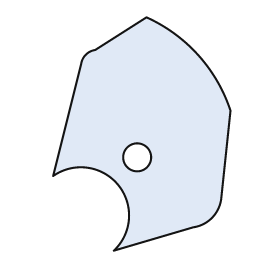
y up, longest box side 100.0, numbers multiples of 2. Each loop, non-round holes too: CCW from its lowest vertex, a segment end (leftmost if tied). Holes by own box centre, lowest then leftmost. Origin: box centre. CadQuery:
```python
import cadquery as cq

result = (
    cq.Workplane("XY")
    .moveTo(-12.0, -50.0)
    .lineTo(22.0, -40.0)
    .threePointArc((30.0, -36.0), (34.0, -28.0))
    .lineTo(38.0, 10.0)
    .threePointArc((24.0, 34.0), (2.0, 50.0))
    .lineTo(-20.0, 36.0)
    .threePointArc((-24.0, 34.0), (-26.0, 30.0))
    .lineTo(-38.0, -18.0)
    .threePointArc((-10.0, -22.0), (-12.0, -50.0))
    .close()
    .moveTo(-2.0, -10.0)
    .circle(6.0)
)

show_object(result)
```